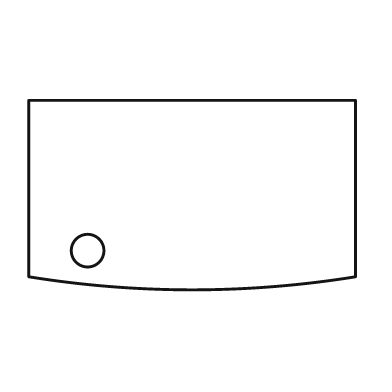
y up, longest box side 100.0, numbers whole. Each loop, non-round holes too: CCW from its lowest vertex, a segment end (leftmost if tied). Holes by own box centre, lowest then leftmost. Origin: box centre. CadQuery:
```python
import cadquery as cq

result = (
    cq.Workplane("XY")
    .moveTo(-50.0, -25.0)
    .threePointArc((0.0, -29.0), (50.0, -25.0))
    .lineTo(50.0, 29.0)
    .lineTo(-50.0, 29.0)
    .close()
    .moveTo(-32.0, -17.0)
    .circle(5.0)
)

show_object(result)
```